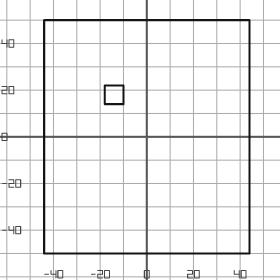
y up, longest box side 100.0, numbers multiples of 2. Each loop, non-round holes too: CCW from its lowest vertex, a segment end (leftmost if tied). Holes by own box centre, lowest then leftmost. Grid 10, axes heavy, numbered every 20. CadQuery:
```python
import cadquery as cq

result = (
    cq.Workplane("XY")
    .moveTo(-44.0, -50.0)
    .lineTo(44.0, -50.0)
    .lineTo(44.0, 50.0)
    .lineTo(-44.0, 50.0)
    .close()
    .moveTo(-18.0, 14.0)
    .lineTo(-10.0, 14.0)
    .lineTo(-10.0, 22.0)
    .lineTo(-18.0, 22.0)
    .close()
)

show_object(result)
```